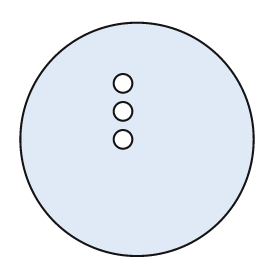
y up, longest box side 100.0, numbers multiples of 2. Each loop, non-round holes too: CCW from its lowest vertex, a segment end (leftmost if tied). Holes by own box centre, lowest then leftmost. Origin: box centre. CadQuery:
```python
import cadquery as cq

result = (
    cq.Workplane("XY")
    .moveTo(0.0, 0.0)
    .circle(50.0)
    .moveTo(-6.0, 0.0)
    .circle(4.0)
    .moveTo(-6.0, 12.0)
    .circle(4.0)
    .moveTo(-6.0, 24.0)
    .circle(4.0)
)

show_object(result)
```